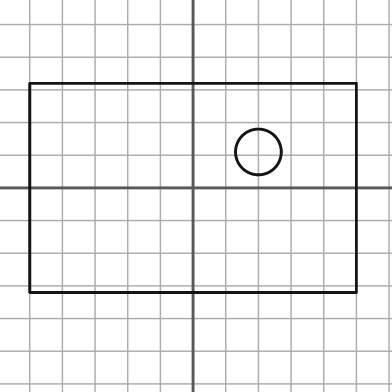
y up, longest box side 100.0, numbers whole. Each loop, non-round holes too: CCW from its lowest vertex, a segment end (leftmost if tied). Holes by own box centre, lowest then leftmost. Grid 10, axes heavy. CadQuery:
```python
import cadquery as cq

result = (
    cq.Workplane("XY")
    .moveTo(-50.0, -32.0)
    .lineTo(50.0, -32.0)
    .lineTo(50.0, 32.0)
    .lineTo(-50.0, 32.0)
    .close()
    .moveTo(20.0, 11.0)
    .circle(7.0)
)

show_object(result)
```